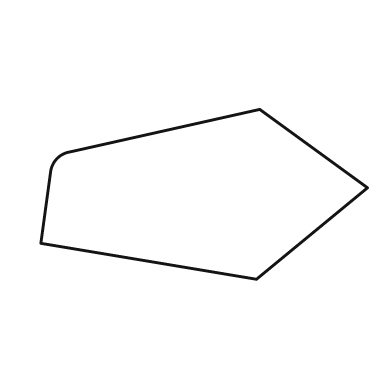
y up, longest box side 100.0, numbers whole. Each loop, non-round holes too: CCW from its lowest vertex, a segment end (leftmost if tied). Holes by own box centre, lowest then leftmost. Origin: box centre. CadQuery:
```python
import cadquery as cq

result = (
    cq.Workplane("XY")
    .moveTo(16.0, -26.0)
    .lineTo(50.0, 2.0)
    .lineTo(17.0, 26.0)
    .lineTo(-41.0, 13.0)
    .threePointArc((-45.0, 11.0), (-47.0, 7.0))
    .lineTo(-50.0, -15.0)
    .close()
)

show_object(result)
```